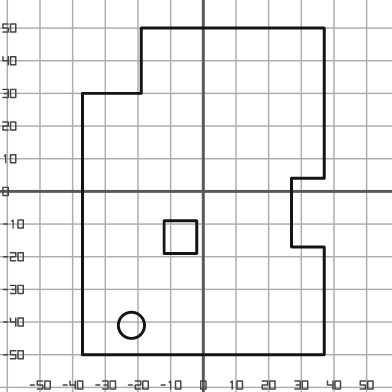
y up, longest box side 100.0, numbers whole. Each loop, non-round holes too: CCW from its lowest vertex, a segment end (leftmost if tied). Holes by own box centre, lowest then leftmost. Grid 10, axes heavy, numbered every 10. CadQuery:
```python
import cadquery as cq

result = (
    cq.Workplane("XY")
    .moveTo(-37.0, -50.0)
    .lineTo(37.0, -50.0)
    .lineTo(37.0, -17.0)
    .lineTo(27.0, -17.0)
    .lineTo(27.0, 4.0)
    .lineTo(37.0, 4.0)
    .lineTo(37.0, 50.0)
    .lineTo(-19.0, 50.0)
    .lineTo(-19.0, 30.0)
    .lineTo(-37.0, 30.0)
    .close()
    .moveTo(-22.0, -41.0)
    .circle(4.0)
    .moveTo(-12.0, -19.0)
    .lineTo(-2.0, -19.0)
    .lineTo(-2.0, -9.0)
    .lineTo(-12.0, -9.0)
    .close()
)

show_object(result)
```